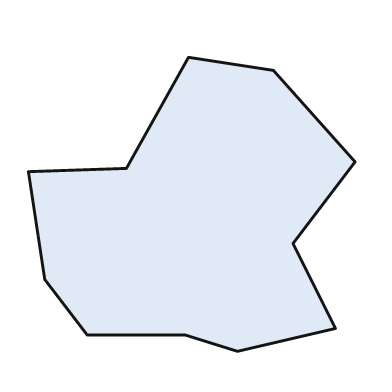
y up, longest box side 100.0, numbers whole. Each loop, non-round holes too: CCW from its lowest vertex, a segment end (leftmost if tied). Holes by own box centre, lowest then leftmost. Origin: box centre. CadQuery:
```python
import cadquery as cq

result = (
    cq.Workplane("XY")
    .moveTo(14.0, -45.0)
    .lineTo(44.0, -38.0)
    .lineTo(31.0, -12.0)
    .lineTo(50.0, 13.0)
    .lineTo(25.0, 41.0)
    .lineTo(-1.0, 45.0)
    .lineTo(-20.0, 11.0)
    .lineTo(-50.0, 10.0)
    .lineTo(-45.0, -23.0)
    .lineTo(-32.0, -40.0)
    .lineTo(-2.0, -40.0)
    .close()
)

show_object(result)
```